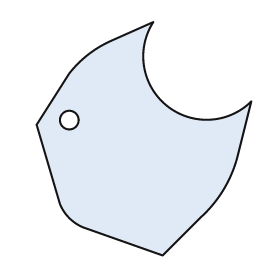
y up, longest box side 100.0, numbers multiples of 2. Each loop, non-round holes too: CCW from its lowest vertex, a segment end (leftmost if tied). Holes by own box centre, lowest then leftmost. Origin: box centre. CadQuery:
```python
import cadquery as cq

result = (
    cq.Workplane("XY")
    .moveTo(8.0, -50.0)
    .lineTo(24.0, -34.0)
    .threePointArc((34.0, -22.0), (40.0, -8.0))
    .lineTo(46.0, 16.0)
    .threePointArc((10.0, 14.0), (4.0, 50.0))
    .lineTo(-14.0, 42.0)
    .threePointArc((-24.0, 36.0), (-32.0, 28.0))
    .lineTo(-46.0, 6.0)
    .lineTo(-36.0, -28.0)
    .threePointArc((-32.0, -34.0), (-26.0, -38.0))
    .close()
    .moveTo(-32.0, 8.0)
    .circle(4.0)
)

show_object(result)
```